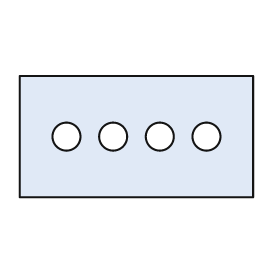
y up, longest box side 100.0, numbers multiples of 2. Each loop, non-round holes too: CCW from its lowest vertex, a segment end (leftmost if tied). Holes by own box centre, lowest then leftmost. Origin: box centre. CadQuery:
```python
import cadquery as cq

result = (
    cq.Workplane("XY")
    .moveTo(-50.0, -26.0)
    .lineTo(50.0, -26.0)
    .lineTo(50.0, 26.0)
    .lineTo(-50.0, 26.0)
    .close()
    .moveTo(-30.0, 0.0)
    .circle(6.0)
    .moveTo(-10.0, 0.0)
    .circle(6.0)
    .moveTo(10.0, 0.0)
    .circle(6.0)
    .moveTo(30.0, 0.0)
    .circle(6.0)
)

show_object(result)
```